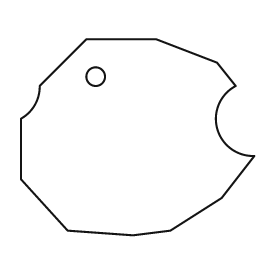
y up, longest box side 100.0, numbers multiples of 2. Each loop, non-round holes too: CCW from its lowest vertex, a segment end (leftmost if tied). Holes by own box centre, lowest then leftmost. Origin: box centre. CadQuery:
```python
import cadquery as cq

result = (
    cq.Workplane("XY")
    .moveTo(-2.0, -42.0)
    .lineTo(14.0, -40.0)
    .lineTo(36.0, -26.0)
    .lineTo(50.0, -8.0)
    .threePointArc((34.0, 4.0), (42.0, 22.0))
    .lineTo(34.0, 32.0)
    .lineTo(8.0, 42.0)
    .lineTo(-22.0, 42.0)
    .lineTo(-42.0, 22.0)
    .threePointArc((-44.0, 14.0), (-50.0, 8.0))
    .lineTo(-50.0, -18.0)
    .lineTo(-30.0, -40.0)
    .close()
    .moveTo(-18.0, 26.0)
    .circle(4.0)
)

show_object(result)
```